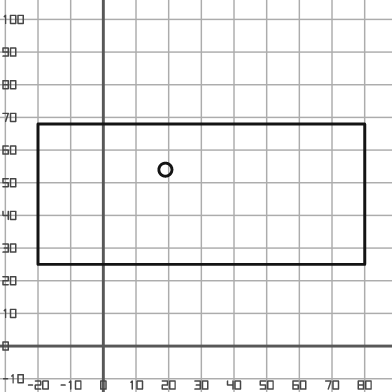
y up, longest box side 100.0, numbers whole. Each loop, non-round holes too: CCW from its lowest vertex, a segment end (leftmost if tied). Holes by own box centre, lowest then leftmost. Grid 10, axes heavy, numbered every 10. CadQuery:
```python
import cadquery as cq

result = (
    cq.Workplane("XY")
    .moveTo(-20.0, 25.0)
    .lineTo(80.0, 25.0)
    .lineTo(80.0, 68.0)
    .lineTo(-20.0, 68.0)
    .close()
    .moveTo(19.0, 54.0)
    .circle(2.0)
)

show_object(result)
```